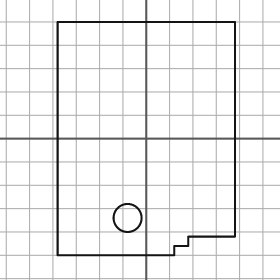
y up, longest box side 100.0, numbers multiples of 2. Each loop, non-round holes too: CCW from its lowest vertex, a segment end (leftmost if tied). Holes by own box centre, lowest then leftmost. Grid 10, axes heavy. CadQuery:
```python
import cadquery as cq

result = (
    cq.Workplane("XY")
    .moveTo(-38.0, -50.0)
    .lineTo(12.0, -50.0)
    .lineTo(12.0, -46.0)
    .lineTo(18.0, -46.0)
    .lineTo(18.0, -42.0)
    .lineTo(38.0, -42.0)
    .lineTo(38.0, 50.0)
    .lineTo(-38.0, 50.0)
    .close()
    .moveTo(-8.0, -34.0)
    .circle(6.0)
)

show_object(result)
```